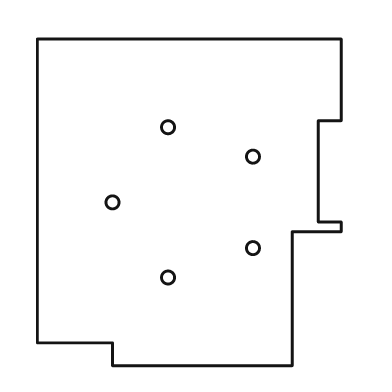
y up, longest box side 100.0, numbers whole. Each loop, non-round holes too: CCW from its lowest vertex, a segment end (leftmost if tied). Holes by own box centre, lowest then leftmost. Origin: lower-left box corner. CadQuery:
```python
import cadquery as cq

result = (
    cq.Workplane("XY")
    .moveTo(23.0, 0.0)
    .lineTo(78.0, 0.0)
    .lineTo(78.0, 41.0)
    .lineTo(93.0, 41.0)
    .lineTo(93.0, 44.0)
    .lineTo(86.0, 44.0)
    .lineTo(86.0, 75.0)
    .lineTo(93.0, 75.0)
    .lineTo(93.0, 100.0)
    .lineTo(0.0, 100.0)
    .lineTo(0.0, 7.0)
    .lineTo(23.0, 7.0)
    .close()
    .moveTo(40.0, 27.0)
    .circle(2.0)
    .moveTo(66.0, 36.0)
    .circle(2.0)
    .moveTo(23.0, 50.0)
    .circle(2.0)
    .moveTo(66.0, 64.0)
    .circle(2.0)
    .moveTo(40.0, 73.0)
    .circle(2.0)
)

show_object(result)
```